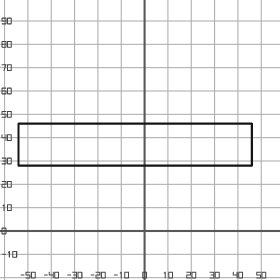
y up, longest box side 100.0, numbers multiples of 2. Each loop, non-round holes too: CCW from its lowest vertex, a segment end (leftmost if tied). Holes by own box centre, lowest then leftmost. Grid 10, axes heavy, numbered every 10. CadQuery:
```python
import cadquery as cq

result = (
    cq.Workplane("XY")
    .moveTo(-54.0, 28.0)
    .lineTo(46.0, 28.0)
    .lineTo(46.0, 46.0)
    .lineTo(-54.0, 46.0)
    .close()
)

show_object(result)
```